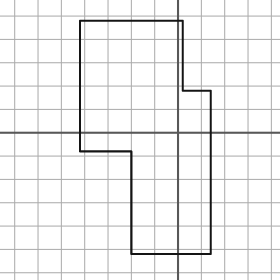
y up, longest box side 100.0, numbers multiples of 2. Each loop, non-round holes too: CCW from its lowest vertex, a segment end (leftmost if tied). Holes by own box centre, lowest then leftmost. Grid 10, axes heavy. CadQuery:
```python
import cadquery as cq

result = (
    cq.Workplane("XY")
    .moveTo(-20.0, -52.0)
    .lineTo(14.0, -52.0)
    .lineTo(14.0, 18.0)
    .lineTo(2.0, 18.0)
    .lineTo(2.0, 48.0)
    .lineTo(-42.0, 48.0)
    .lineTo(-42.0, -8.0)
    .lineTo(-20.0, -8.0)
    .close()
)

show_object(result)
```